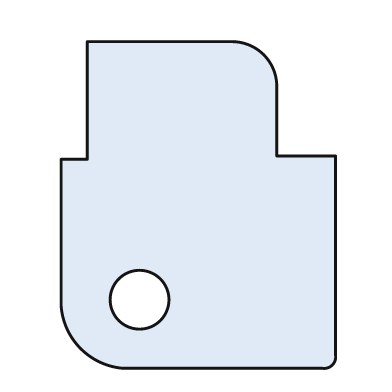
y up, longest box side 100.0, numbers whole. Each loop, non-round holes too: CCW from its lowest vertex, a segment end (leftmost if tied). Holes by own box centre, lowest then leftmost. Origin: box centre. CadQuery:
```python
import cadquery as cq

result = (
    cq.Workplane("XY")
    .moveTo(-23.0, -50.0)
    .lineTo(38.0, -50.0)
    .threePointArc((41.0, -49.0), (42.0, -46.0))
    .lineTo(42.0, 15.0)
    .lineTo(24.0, 15.0)
    .lineTo(24.0, 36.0)
    .threePointArc((20.0, 46.0), (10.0, 50.0))
    .lineTo(-34.0, 50.0)
    .lineTo(-34.0, 14.0)
    .lineTo(-42.0, 14.0)
    .lineTo(-42.0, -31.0)
    .threePointArc((-36.0, -44.0), (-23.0, -50.0))
    .close()
    .moveTo(-18.0, -29.0)
    .circle(9.0)
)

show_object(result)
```